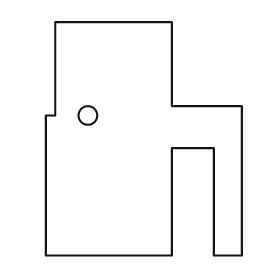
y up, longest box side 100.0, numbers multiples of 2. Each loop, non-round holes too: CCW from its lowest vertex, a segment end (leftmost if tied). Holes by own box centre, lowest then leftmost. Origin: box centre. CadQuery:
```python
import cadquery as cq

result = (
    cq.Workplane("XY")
    .moveTo(-42.0, -50.0)
    .lineTo(12.0, -50.0)
    .lineTo(12.0, -4.0)
    .lineTo(30.0, -4.0)
    .lineTo(30.0, -50.0)
    .lineTo(42.0, -50.0)
    .lineTo(42.0, 14.0)
    .lineTo(12.0, 14.0)
    .lineTo(12.0, 50.0)
    .lineTo(-38.0, 50.0)
    .lineTo(-38.0, 10.0)
    .lineTo(-42.0, 10.0)
    .close()
    .moveTo(-24.0, 10.0)
    .circle(4.0)
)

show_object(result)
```